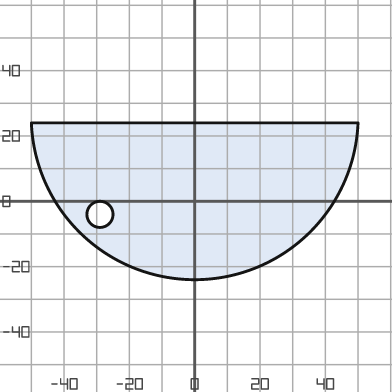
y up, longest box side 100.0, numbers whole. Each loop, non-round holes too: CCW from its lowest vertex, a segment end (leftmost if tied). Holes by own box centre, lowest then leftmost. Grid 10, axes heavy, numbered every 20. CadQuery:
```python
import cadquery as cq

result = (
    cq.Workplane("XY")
    .moveTo(-50.0, 24.0)
    .threePointArc((0.0, -24.0), (50.0, 24.0))
    .close()
    .moveTo(-29.0, -4.0)
    .circle(4.0)
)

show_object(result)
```